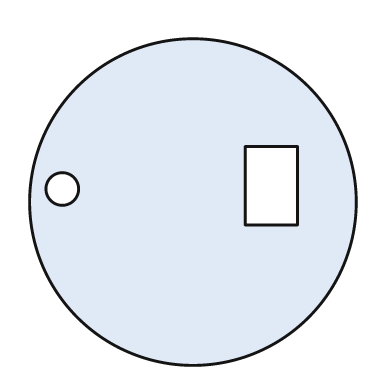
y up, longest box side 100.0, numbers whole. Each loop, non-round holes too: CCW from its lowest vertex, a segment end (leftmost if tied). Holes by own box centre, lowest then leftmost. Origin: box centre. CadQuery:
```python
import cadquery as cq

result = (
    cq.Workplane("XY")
    .moveTo(0.0, 0.0)
    .circle(50.0)
    .moveTo(-40.0, 4.0)
    .circle(5.0)
    .moveTo(16.0, -7.0)
    .lineTo(32.0, -7.0)
    .lineTo(32.0, 17.0)
    .lineTo(16.0, 17.0)
    .close()
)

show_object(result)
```